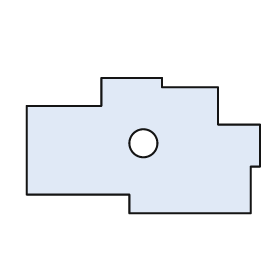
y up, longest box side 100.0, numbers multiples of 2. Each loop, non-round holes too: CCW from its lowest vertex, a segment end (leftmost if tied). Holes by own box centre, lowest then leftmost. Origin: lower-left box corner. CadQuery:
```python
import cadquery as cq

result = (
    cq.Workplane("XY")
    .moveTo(44.0, 0.0)
    .lineTo(96.0, 0.0)
    .lineTo(96.0, 20.0)
    .lineTo(100.0, 20.0)
    .lineTo(100.0, 38.0)
    .lineTo(82.0, 38.0)
    .lineTo(82.0, 54.0)
    .lineTo(58.0, 54.0)
    .lineTo(58.0, 58.0)
    .lineTo(32.0, 58.0)
    .lineTo(32.0, 46.0)
    .lineTo(0.0, 46.0)
    .lineTo(0.0, 8.0)
    .lineTo(44.0, 8.0)
    .close()
    .moveTo(50.0, 30.0)
    .circle(6.0)
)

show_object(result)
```